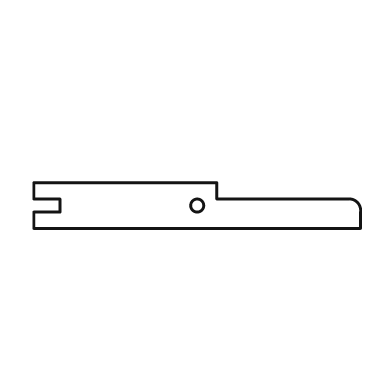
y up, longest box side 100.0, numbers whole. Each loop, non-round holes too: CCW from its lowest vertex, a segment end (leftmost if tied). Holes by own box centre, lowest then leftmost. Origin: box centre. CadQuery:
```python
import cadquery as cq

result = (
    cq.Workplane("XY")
    .moveTo(-50.0, -7.0)
    .lineTo(50.0, -7.0)
    .lineTo(50.0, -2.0)
    .threePointArc((49.0, 1.0), (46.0, 2.0))
    .lineTo(6.0, 2.0)
    .lineTo(6.0, 7.0)
    .lineTo(-50.0, 7.0)
    .lineTo(-50.0, 2.0)
    .lineTo(-42.0, 2.0)
    .lineTo(-42.0, -2.0)
    .lineTo(-50.0, -2.0)
    .close()
    .moveTo(0.0, 0.0)
    .circle(2.0)
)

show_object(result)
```